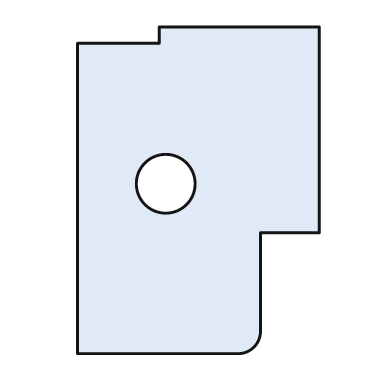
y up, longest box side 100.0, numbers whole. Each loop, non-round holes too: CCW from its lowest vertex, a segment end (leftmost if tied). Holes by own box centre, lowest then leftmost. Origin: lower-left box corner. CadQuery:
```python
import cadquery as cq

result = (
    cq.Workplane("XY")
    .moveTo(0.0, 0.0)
    .lineTo(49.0, 0.0)
    .threePointArc((54.0, 2.0), (56.0, 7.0))
    .lineTo(56.0, 37.0)
    .lineTo(74.0, 37.0)
    .lineTo(74.0, 100.0)
    .lineTo(25.0, 100.0)
    .lineTo(25.0, 95.0)
    .lineTo(0.0, 95.0)
    .close()
    .moveTo(27.0, 52.0)
    .circle(9.0)
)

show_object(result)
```